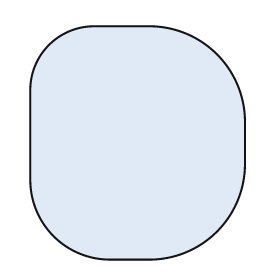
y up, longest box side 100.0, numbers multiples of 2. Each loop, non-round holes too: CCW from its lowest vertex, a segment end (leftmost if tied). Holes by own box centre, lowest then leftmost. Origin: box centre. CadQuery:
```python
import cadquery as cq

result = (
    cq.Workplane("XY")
    .moveTo(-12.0, -50.0)
    .lineTo(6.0, -50.0)
    .threePointArc((34.0, -38.0), (46.0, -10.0))
    .lineTo(46.0, 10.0)
    .threePointArc((34.0, 38.0), (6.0, 50.0))
    .lineTo(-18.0, 50.0)
    .threePointArc((-38.0, 42.0), (-46.0, 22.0))
    .lineTo(-46.0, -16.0)
    .threePointArc((-36.0, -40.0), (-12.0, -50.0))
    .close()
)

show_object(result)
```